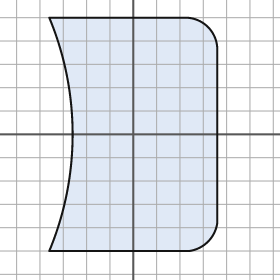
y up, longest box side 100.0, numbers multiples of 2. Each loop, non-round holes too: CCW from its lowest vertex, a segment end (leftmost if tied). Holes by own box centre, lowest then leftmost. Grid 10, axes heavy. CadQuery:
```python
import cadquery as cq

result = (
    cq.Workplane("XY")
    .moveTo(-36.0, -50.0)
    .lineTo(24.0, -50.0)
    .threePointArc((32.0, -46.0), (36.0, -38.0))
    .lineTo(36.0, 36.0)
    .threePointArc((32.0, 46.0), (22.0, 50.0))
    .lineTo(-36.0, 50.0)
    .threePointArc((-26.0, 0.0), (-36.0, -50.0))
    .close()
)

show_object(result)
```